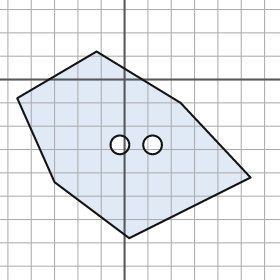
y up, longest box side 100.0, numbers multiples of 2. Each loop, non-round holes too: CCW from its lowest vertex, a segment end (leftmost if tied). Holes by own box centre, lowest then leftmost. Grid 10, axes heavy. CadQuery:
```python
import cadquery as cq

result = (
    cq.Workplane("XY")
    .moveTo(2.0, -68.0)
    .lineTo(54.0, -42.0)
    .lineTo(24.0, -10.0)
    .lineTo(-12.0, 12.0)
    .lineTo(-46.0, -8.0)
    .lineTo(-30.0, -44.0)
    .close()
    .moveTo(-2.0, -28.0)
    .circle(4.0)
    .moveTo(12.0, -28.0)
    .circle(4.0)
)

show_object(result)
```